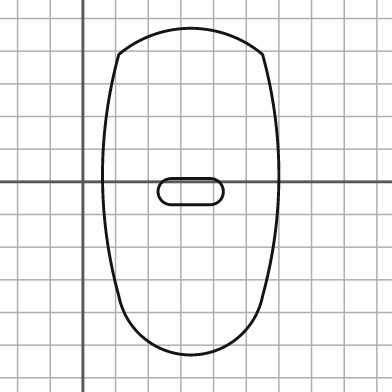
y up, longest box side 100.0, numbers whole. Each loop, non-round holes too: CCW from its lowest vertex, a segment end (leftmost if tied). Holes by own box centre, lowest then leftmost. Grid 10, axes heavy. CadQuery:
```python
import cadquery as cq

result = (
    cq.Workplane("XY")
    .moveTo(11.0, -35.0)
    .threePointArc((33.0, -53.0), (55.0, -35.0))
    .threePointArc((60.0, 2.0), (55.0, 39.0))
    .threePointArc((33.0, 47.0), (11.0, 39.0))
    .threePointArc((6.0, 2.0), (11.0, -35.0))
    .close()
    .moveTo(27.0, -7.0)
    .lineTo(39.0, -7.0)
    .threePointArc((43.0, -3.0), (39.0, 1.0))
    .lineTo(27.0, 1.0)
    .threePointArc((23.0, -3.0), (27.0, -7.0))
    .close()
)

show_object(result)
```